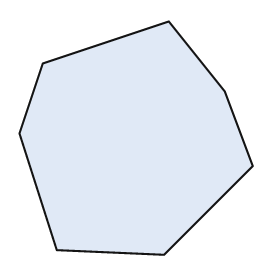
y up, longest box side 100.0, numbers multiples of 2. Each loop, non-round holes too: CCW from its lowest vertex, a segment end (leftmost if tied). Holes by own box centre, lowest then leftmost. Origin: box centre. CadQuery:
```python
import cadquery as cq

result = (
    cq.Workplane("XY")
    .moveTo(12.0, -50.0)
    .lineTo(50.0, -12.0)
    .lineTo(38.0, 20.0)
    .lineTo(14.0, 50.0)
    .lineTo(-40.0, 32.0)
    .lineTo(-50.0, 2.0)
    .lineTo(-34.0, -48.0)
    .close()
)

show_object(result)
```